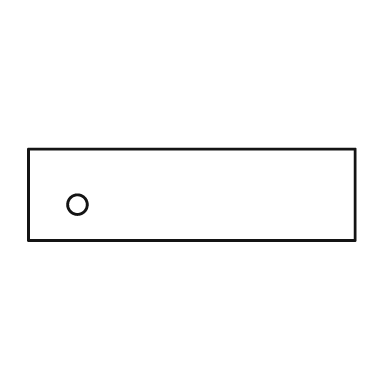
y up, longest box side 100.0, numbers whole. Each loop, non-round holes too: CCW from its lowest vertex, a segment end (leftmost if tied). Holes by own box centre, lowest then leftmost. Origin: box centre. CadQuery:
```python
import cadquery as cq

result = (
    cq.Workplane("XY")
    .moveTo(-50.0, -14.0)
    .lineTo(50.0, -14.0)
    .lineTo(50.0, 14.0)
    .lineTo(-50.0, 14.0)
    .close()
    .moveTo(-35.0, -3.0)
    .circle(3.0)
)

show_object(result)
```